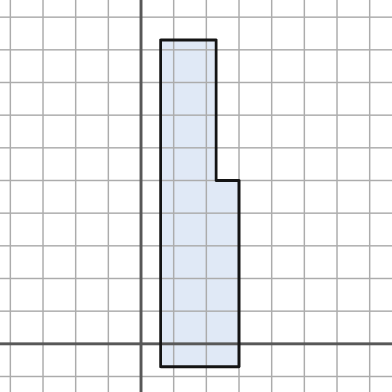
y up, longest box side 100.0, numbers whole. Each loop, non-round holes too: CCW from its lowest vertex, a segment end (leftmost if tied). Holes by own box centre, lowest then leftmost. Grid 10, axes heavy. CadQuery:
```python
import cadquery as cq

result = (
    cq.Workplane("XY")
    .moveTo(6.0, -7.0)
    .lineTo(30.0, -7.0)
    .lineTo(30.0, 50.0)
    .lineTo(23.0, 50.0)
    .lineTo(23.0, 93.0)
    .lineTo(6.0, 93.0)
    .close()
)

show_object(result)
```